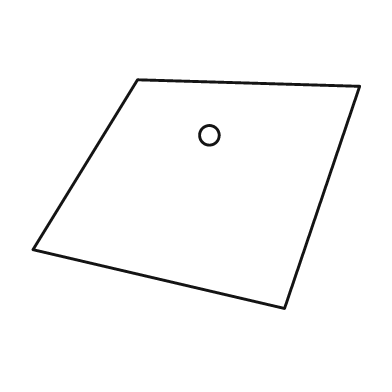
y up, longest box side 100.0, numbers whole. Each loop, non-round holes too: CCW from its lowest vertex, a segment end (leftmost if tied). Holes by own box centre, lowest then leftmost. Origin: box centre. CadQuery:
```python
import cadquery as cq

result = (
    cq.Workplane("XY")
    .moveTo(27.0, -35.0)
    .lineTo(50.0, 33.0)
    .lineTo(-18.0, 35.0)
    .lineTo(-50.0, -17.0)
    .close()
    .moveTo(4.0, 18.0)
    .circle(3.0)
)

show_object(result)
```